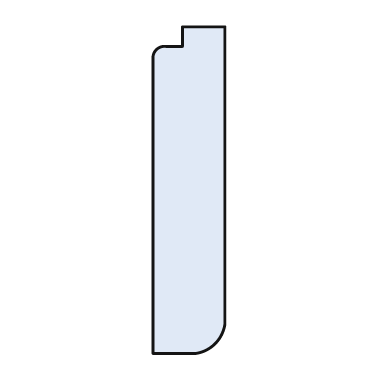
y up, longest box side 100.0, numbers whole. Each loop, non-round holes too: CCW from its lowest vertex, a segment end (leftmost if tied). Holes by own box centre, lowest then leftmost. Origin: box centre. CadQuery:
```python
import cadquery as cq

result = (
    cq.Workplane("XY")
    .moveTo(-11.0, -50.0)
    .lineTo(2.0, -50.0)
    .threePointArc((8.0, -47.0), (11.0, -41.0))
    .lineTo(11.0, 50.0)
    .lineTo(-2.0, 50.0)
    .lineTo(-2.0, 44.0)
    .lineTo(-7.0, 44.0)
    .threePointArc((-10.0, 43.0), (-11.0, 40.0))
    .close()
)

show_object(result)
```